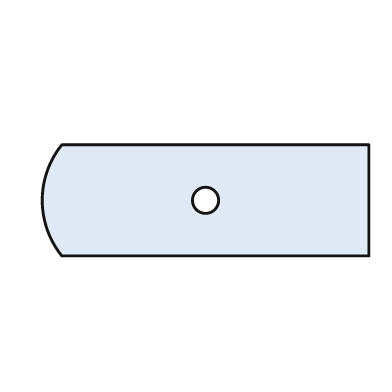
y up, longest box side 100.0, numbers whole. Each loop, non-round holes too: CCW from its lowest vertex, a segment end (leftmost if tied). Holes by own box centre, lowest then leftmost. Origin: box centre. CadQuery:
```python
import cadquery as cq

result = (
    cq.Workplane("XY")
    .moveTo(-44.0, -17.0)
    .lineTo(50.0, -17.0)
    .lineTo(50.0, 17.0)
    .lineTo(-44.0, 17.0)
    .threePointArc((-50.0, 0.0), (-44.0, -17.0))
    .close()
    .moveTo(0.0, 0.0)
    .circle(4.0)
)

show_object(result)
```